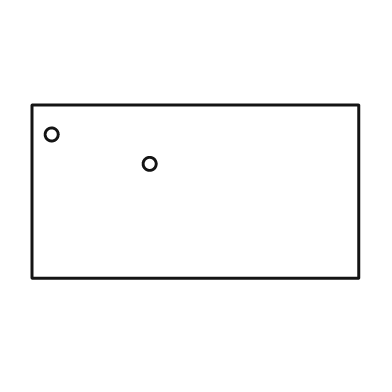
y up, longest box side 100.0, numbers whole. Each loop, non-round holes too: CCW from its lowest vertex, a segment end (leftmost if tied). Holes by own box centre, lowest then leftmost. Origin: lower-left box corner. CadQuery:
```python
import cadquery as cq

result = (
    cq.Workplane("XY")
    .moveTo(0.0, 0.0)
    .lineTo(100.0, 0.0)
    .lineTo(100.0, 53.0)
    .lineTo(0.0, 53.0)
    .close()
    .moveTo(36.0, 35.0)
    .circle(2.0)
    .moveTo(6.0, 44.0)
    .circle(2.0)
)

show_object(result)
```